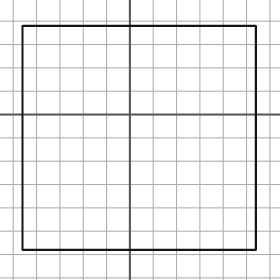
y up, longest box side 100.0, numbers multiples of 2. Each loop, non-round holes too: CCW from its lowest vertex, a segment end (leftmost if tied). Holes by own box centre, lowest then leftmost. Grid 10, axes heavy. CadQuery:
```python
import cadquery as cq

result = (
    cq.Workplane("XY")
    .moveTo(-46.0, -58.0)
    .lineTo(54.0, -58.0)
    .lineTo(54.0, 38.0)
    .lineTo(-46.0, 38.0)
    .close()
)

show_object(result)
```